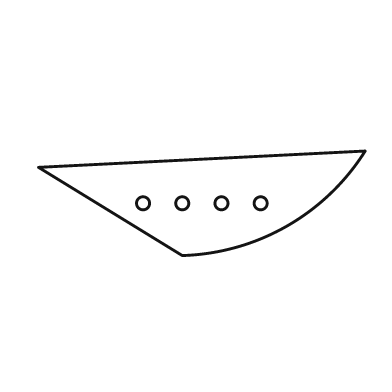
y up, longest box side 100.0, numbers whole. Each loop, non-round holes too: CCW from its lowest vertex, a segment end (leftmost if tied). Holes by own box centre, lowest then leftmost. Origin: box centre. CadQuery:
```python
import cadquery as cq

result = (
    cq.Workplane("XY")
    .moveTo(-6.0, -16.0)
    .threePointArc((26.0, -7.0), (50.0, 16.0))
    .lineTo(-50.0, 11.0)
    .close()
    .moveTo(-18.0, 0.0)
    .circle(2.0)
    .moveTo(-6.0, 0.0)
    .circle(2.0)
    .moveTo(6.0, 0.0)
    .circle(2.0)
    .moveTo(18.0, 0.0)
    .circle(2.0)
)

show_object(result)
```